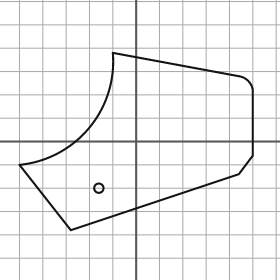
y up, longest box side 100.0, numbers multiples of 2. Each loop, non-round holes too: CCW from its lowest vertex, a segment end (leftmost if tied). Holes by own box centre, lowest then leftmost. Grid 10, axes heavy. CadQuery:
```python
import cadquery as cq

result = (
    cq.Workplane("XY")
    .moveTo(-28.0, -38.0)
    .lineTo(44.0, -14.0)
    .lineTo(50.0, -6.0)
    .lineTo(50.0, 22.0)
    .threePointArc((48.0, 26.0), (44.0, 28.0))
    .lineTo(-10.0, 38.0)
    .threePointArc((-20.0, 6.0), (-50.0, -10.0))
    .close()
    .moveTo(-16.0, -20.0)
    .circle(2.0)
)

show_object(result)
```